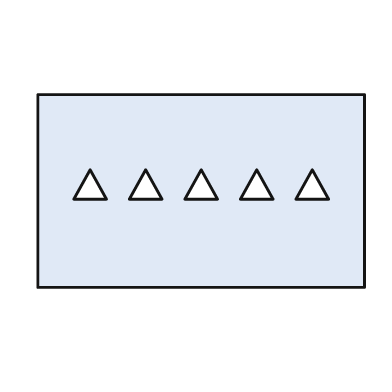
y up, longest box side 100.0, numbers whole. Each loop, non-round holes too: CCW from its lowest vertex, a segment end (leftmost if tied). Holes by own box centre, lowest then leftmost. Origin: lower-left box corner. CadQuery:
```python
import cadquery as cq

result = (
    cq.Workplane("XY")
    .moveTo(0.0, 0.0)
    .lineTo(100.0, 0.0)
    .lineTo(100.0, 59.0)
    .lineTo(0.0, 59.0)
    .close()
    .moveTo(11.0, 27.0)
    .lineTo(21.0, 27.0)
    .lineTo(16.0, 36.0)
    .close()
    .moveTo(28.0, 27.0)
    .lineTo(38.0, 27.0)
    .lineTo(33.0, 36.0)
    .close()
    .moveTo(45.0, 27.0)
    .lineTo(55.0, 27.0)
    .lineTo(50.0, 36.0)
    .close()
    .moveTo(62.0, 27.0)
    .lineTo(72.0, 27.0)
    .lineTo(67.0, 36.0)
    .close()
    .moveTo(79.0, 27.0)
    .lineTo(89.0, 27.0)
    .lineTo(84.0, 36.0)
    .close()
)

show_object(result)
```